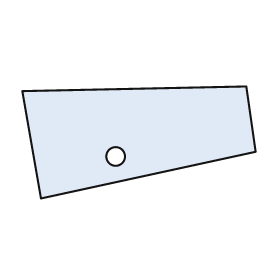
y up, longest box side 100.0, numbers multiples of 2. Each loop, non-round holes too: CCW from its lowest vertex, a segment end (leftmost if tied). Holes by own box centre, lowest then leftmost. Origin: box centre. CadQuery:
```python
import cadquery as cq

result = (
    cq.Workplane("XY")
    .moveTo(-42.0, -24.0)
    .lineTo(50.0, -4.0)
    .lineTo(46.0, 24.0)
    .lineTo(-50.0, 22.0)
    .close()
    .moveTo(-10.0, -6.0)
    .circle(4.0)
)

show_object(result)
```